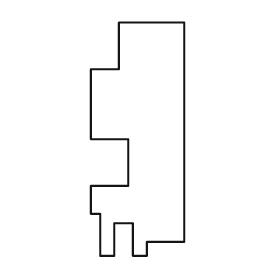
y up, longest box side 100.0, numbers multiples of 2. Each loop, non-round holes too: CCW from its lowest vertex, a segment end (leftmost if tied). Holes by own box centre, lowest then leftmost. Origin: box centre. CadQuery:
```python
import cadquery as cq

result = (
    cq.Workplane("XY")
    .moveTo(-16.0, -50.0)
    .lineTo(-10.0, -50.0)
    .lineTo(-10.0, -36.0)
    .lineTo(-2.0, -36.0)
    .lineTo(-2.0, -50.0)
    .lineTo(4.0, -50.0)
    .lineTo(4.0, -44.0)
    .lineTo(20.0, -44.0)
    .lineTo(20.0, 50.0)
    .lineTo(-8.0, 50.0)
    .lineTo(-8.0, 30.0)
    .lineTo(-20.0, 30.0)
    .lineTo(-20.0, 0.0)
    .lineTo(-4.0, 0.0)
    .lineTo(-4.0, -20.0)
    .lineTo(-20.0, -20.0)
    .lineTo(-20.0, -32.0)
    .lineTo(-16.0, -32.0)
    .close()
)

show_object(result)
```